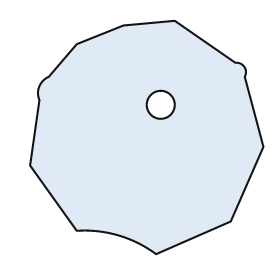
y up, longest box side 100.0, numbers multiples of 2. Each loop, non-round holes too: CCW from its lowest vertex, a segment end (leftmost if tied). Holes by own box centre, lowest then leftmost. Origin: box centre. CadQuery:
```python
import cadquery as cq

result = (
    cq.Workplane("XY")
    .moveTo(4.0, -50.0)
    .lineTo(36.0, -36.0)
    .lineTo(50.0, -4.0)
    .lineTo(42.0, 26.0)
    .threePointArc((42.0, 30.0), (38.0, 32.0))
    .lineTo(12.0, 50.0)
    .lineTo(-10.0, 48.0)
    .lineTo(-30.0, 40.0)
    .lineTo(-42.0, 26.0)
    .threePointArc((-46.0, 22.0), (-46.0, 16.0))
    .lineTo(-50.0, -12.0)
    .lineTo(-30.0, -40.0)
    .threePointArc((-12.0, -42.0), (4.0, -50.0))
    .close()
    .moveTo(6.0, 14.0)
    .circle(6.0)
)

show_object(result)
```